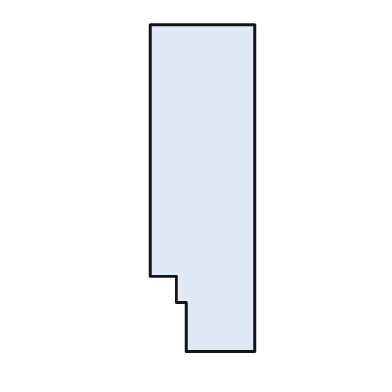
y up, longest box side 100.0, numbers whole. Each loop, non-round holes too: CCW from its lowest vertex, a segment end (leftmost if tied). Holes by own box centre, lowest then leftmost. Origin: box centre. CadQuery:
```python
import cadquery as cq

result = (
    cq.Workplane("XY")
    .moveTo(-5.0, -50.0)
    .lineTo(16.0, -50.0)
    .lineTo(16.0, 50.0)
    .lineTo(-16.0, 50.0)
    .lineTo(-16.0, -27.0)
    .lineTo(-8.0, -27.0)
    .lineTo(-8.0, -35.0)
    .lineTo(-5.0, -35.0)
    .close()
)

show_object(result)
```